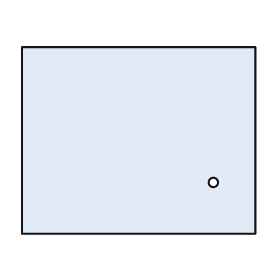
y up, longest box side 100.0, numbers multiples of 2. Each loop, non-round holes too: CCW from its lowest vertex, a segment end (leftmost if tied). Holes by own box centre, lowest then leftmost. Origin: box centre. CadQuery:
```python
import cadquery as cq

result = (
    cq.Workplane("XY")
    .moveTo(-50.0, -40.0)
    .lineTo(50.0, -40.0)
    .lineTo(50.0, 40.0)
    .lineTo(-50.0, 40.0)
    .close()
    .moveTo(32.0, -18.0)
    .circle(2.0)
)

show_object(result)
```